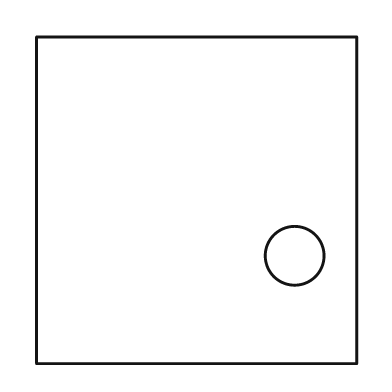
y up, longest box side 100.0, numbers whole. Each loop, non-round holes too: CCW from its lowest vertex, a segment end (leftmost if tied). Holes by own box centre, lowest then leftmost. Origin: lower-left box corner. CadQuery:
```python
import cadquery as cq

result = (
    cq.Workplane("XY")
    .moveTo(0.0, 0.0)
    .lineTo(98.0, 0.0)
    .lineTo(98.0, 100.0)
    .lineTo(0.0, 100.0)
    .close()
    .moveTo(79.0, 33.0)
    .circle(9.0)
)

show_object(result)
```